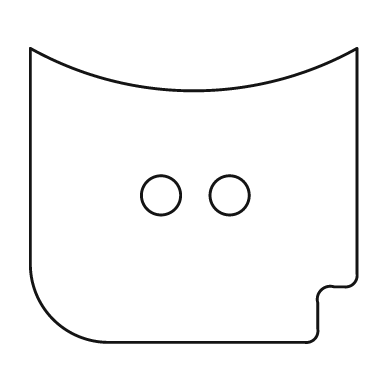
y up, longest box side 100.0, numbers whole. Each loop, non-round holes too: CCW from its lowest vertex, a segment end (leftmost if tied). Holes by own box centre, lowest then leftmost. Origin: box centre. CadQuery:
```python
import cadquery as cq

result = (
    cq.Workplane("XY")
    .moveTo(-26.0, -45.0)
    .lineTo(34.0, -45.0)
    .threePointArc((37.0, -44.0), (38.0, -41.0))
    .lineTo(38.0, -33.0)
    .threePointArc((39.0, -29.0), (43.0, -28.0))
    .lineTo(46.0, -28.0)
    .threePointArc((49.0, -27.0), (50.0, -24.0))
    .lineTo(50.0, 45.0)
    .threePointArc((0.0, 32.0), (-50.0, 45.0))
    .lineTo(-50.0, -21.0)
    .threePointArc((-43.0, -38.0), (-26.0, -45.0))
    .close()
    .moveTo(-10.0, 0.0)
    .circle(6.0)
    .moveTo(11.0, 0.0)
    .circle(6.0)
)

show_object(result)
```